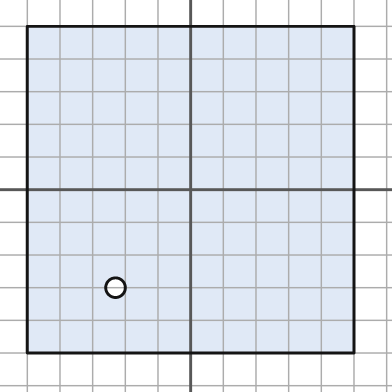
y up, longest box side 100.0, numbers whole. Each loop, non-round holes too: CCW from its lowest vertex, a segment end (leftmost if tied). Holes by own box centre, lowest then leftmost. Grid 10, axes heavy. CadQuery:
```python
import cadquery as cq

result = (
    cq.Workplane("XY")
    .moveTo(-50.0, -50.0)
    .lineTo(50.0, -50.0)
    .lineTo(50.0, 50.0)
    .lineTo(-50.0, 50.0)
    .close()
    .moveTo(-23.0, -30.0)
    .circle(3.0)
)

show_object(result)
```